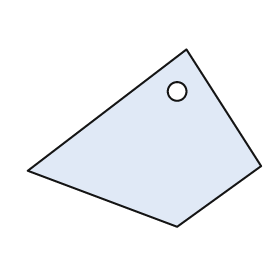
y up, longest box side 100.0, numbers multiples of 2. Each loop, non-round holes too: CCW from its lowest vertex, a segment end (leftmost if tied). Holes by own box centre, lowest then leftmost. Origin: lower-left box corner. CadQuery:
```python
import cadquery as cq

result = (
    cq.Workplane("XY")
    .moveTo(64.0, 0.0)
    .lineTo(100.0, 26.0)
    .lineTo(68.0, 76.0)
    .lineTo(0.0, 24.0)
    .close()
    .moveTo(64.0, 58.0)
    .circle(4.0)
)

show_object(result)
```